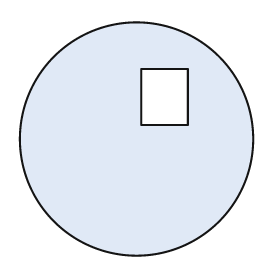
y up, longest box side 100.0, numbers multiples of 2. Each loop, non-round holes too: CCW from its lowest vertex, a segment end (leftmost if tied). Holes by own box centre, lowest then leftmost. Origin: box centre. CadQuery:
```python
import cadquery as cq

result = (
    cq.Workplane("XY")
    .moveTo(0.0, 0.0)
    .circle(50.0)
    .moveTo(2.0, 6.0)
    .lineTo(22.0, 6.0)
    .lineTo(22.0, 30.0)
    .lineTo(2.0, 30.0)
    .close()
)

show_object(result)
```